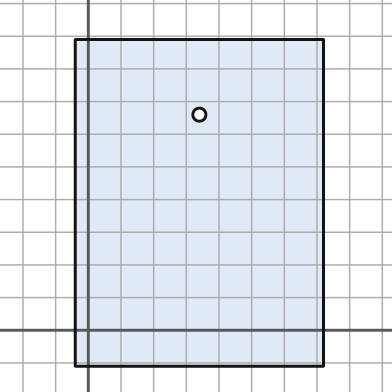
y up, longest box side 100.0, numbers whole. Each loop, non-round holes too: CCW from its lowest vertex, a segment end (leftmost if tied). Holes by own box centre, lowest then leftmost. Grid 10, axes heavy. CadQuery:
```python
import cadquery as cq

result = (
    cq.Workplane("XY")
    .moveTo(-4.0, -11.0)
    .lineTo(72.0, -11.0)
    .lineTo(72.0, 89.0)
    .lineTo(-4.0, 89.0)
    .close()
    .moveTo(34.0, 66.0)
    .circle(2.0)
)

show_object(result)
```